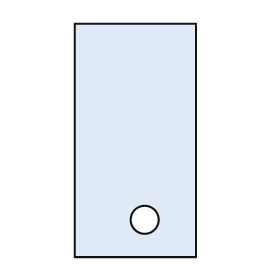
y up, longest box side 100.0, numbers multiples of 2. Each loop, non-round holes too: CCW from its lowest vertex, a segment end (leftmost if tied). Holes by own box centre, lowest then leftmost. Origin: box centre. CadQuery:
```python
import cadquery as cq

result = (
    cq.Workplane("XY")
    .moveTo(-26.0, -50.0)
    .lineTo(26.0, -50.0)
    .lineTo(26.0, 50.0)
    .lineTo(-26.0, 50.0)
    .close()
    .moveTo(4.0, -34.0)
    .circle(6.0)
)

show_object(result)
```